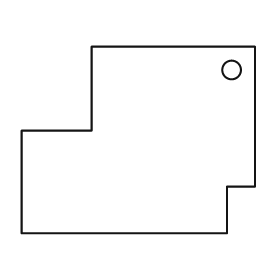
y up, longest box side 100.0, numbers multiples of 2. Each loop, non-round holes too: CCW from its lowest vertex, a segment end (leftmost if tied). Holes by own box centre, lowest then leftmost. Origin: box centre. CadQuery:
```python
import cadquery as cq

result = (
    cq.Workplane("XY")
    .moveTo(-50.0, -40.0)
    .lineTo(38.0, -40.0)
    .lineTo(38.0, -20.0)
    .lineTo(50.0, -20.0)
    .lineTo(50.0, 40.0)
    .lineTo(-20.0, 40.0)
    .lineTo(-20.0, 4.0)
    .lineTo(-50.0, 4.0)
    .close()
    .moveTo(40.0, 30.0)
    .circle(4.0)
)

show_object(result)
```